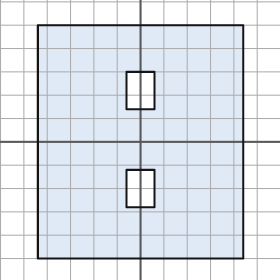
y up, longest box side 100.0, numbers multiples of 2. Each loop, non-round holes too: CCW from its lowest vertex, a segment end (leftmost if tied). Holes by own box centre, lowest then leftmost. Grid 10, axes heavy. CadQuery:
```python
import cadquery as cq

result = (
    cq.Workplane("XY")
    .moveTo(-44.0, -50.0)
    .lineTo(44.0, -50.0)
    .lineTo(44.0, 50.0)
    .lineTo(-44.0, 50.0)
    .close()
    .moveTo(-6.0, -28.0)
    .lineTo(6.0, -28.0)
    .lineTo(6.0, -12.0)
    .lineTo(-6.0, -12.0)
    .close()
    .moveTo(-6.0, 14.0)
    .lineTo(6.0, 14.0)
    .lineTo(6.0, 30.0)
    .lineTo(-6.0, 30.0)
    .close()
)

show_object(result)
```